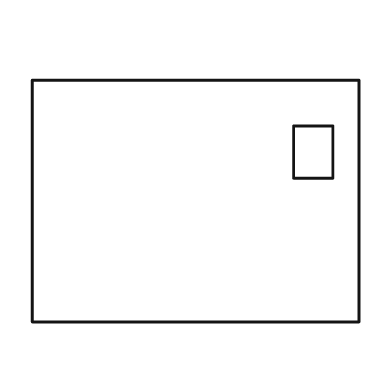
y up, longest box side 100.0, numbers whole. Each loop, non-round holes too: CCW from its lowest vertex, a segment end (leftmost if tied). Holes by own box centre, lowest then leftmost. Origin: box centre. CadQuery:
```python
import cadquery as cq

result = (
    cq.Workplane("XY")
    .moveTo(-50.0, -37.0)
    .lineTo(50.0, -37.0)
    .lineTo(50.0, 37.0)
    .lineTo(-50.0, 37.0)
    .close()
    .moveTo(30.0, 7.0)
    .lineTo(42.0, 7.0)
    .lineTo(42.0, 23.0)
    .lineTo(30.0, 23.0)
    .close()
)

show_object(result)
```